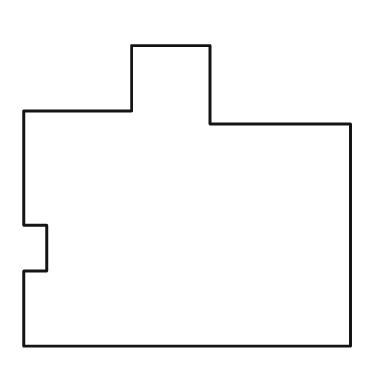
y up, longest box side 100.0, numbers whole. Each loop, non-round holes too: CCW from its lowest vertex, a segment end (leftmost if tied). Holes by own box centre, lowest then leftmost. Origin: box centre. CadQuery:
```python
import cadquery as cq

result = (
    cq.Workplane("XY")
    .moveTo(-50.0, -46.0)
    .lineTo(50.0, -46.0)
    .lineTo(50.0, 22.0)
    .lineTo(7.0, 22.0)
    .lineTo(7.0, 46.0)
    .lineTo(-17.0, 46.0)
    .lineTo(-17.0, 26.0)
    .lineTo(-50.0, 26.0)
    .lineTo(-50.0, -9.0)
    .lineTo(-43.0, -9.0)
    .lineTo(-43.0, -23.0)
    .lineTo(-50.0, -23.0)
    .close()
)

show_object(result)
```